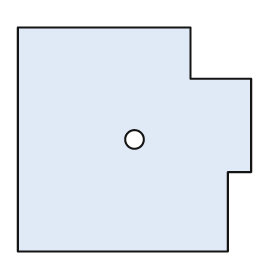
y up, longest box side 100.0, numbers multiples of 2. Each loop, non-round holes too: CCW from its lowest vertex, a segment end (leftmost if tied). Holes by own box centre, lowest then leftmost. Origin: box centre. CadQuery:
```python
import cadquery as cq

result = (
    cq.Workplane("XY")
    .moveTo(-50.0, -48.0)
    .lineTo(40.0, -48.0)
    .lineTo(40.0, -14.0)
    .lineTo(50.0, -14.0)
    .lineTo(50.0, 26.0)
    .lineTo(24.0, 26.0)
    .lineTo(24.0, 48.0)
    .lineTo(-50.0, 48.0)
    .close()
    .moveTo(0.0, 0.0)
    .circle(4.0)
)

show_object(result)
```